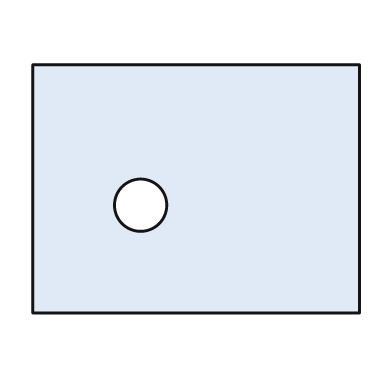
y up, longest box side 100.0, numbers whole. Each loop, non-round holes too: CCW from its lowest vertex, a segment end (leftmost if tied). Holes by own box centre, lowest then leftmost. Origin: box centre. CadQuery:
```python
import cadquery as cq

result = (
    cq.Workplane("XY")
    .moveTo(-50.0, -38.0)
    .lineTo(50.0, -38.0)
    .lineTo(50.0, 38.0)
    .lineTo(-50.0, 38.0)
    .close()
    .moveTo(-17.0, -5.0)
    .circle(8.0)
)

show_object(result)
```